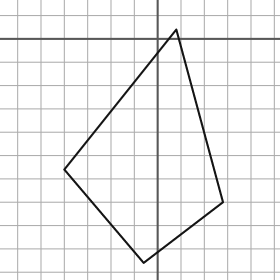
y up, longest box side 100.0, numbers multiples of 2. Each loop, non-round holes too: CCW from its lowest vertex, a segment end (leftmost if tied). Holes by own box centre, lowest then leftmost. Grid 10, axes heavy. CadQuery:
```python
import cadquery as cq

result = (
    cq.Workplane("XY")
    .moveTo(-6.0, -96.0)
    .lineTo(28.0, -70.0)
    .lineTo(8.0, 4.0)
    .lineTo(-40.0, -56.0)
    .close()
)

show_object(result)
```